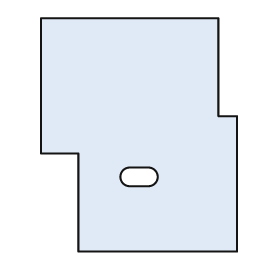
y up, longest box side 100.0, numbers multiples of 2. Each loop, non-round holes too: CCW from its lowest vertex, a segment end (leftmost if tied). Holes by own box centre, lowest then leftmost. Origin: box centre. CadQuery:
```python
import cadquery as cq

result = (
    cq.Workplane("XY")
    .moveTo(-26.0, -50.0)
    .lineTo(42.0, -50.0)
    .lineTo(42.0, 8.0)
    .lineTo(34.0, 8.0)
    .lineTo(34.0, 50.0)
    .lineTo(-42.0, 50.0)
    .lineTo(-42.0, -8.0)
    .lineTo(-26.0, -8.0)
    .close()
    .moveTo(-4.0, -22.0)
    .lineTo(4.0, -22.0)
    .threePointArc((8.0, -18.0), (4.0, -14.0))
    .lineTo(-4.0, -14.0)
    .threePointArc((-8.0, -18.0), (-4.0, -22.0))
    .close()
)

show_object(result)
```